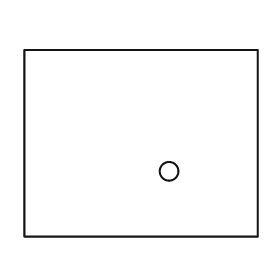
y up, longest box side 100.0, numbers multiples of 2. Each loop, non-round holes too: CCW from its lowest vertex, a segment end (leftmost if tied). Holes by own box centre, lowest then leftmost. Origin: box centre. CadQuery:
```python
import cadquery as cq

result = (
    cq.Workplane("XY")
    .moveTo(-50.0, -40.0)
    .lineTo(50.0, -40.0)
    .lineTo(50.0, 40.0)
    .lineTo(-50.0, 40.0)
    .close()
    .moveTo(12.0, -12.0)
    .circle(4.0)
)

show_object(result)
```